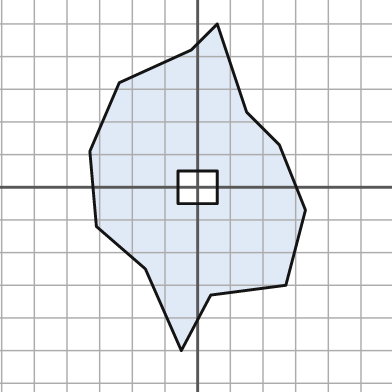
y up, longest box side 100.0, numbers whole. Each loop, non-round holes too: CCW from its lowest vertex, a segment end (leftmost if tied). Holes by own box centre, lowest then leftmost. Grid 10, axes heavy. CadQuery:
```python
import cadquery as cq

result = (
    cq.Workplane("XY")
    .moveTo(-5.0, -50.0)
    .lineTo(4.0, -33.0)
    .lineTo(27.0, -30.0)
    .lineTo(33.0, -7.0)
    .lineTo(25.0, 13.0)
    .lineTo(15.0, 23.0)
    .lineTo(6.0, 50.0)
    .lineTo(-2.0, 42.0)
    .lineTo(-24.0, 32.0)
    .lineTo(-33.0, 11.0)
    .lineTo(-31.0, -12.0)
    .lineTo(-16.0, -25.0)
    .close()
    .moveTo(-6.0, -5.0)
    .lineTo(6.0, -5.0)
    .lineTo(6.0, 5.0)
    .lineTo(-6.0, 5.0)
    .close()
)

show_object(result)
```